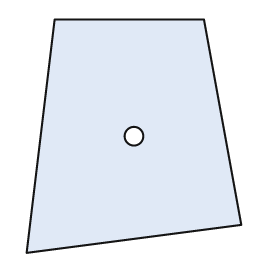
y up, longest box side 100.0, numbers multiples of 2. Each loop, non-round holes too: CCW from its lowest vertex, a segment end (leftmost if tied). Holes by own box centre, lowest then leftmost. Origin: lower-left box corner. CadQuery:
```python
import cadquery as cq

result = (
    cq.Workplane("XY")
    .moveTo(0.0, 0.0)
    .lineTo(92.0, 12.0)
    .lineTo(76.0, 100.0)
    .lineTo(12.0, 100.0)
    .close()
    .moveTo(46.0, 50.0)
    .circle(4.0)
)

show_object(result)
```